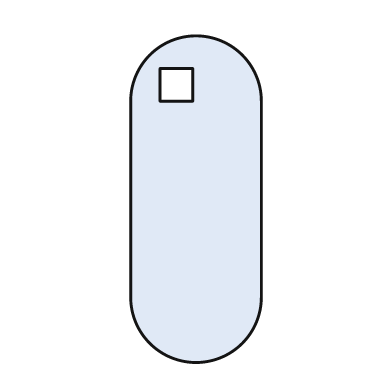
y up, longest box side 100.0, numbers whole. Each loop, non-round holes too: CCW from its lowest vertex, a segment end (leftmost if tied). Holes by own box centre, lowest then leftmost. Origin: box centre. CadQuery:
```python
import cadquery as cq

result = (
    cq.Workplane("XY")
    .moveTo(-20.0, -30.0)
    .threePointArc((0.0, -50.0), (20.0, -30.0))
    .lineTo(20.0, 30.0)
    .threePointArc((0.0, 50.0), (-20.0, 30.0))
    .close()
    .moveTo(-11.0, 30.0)
    .lineTo(-1.0, 30.0)
    .lineTo(-1.0, 40.0)
    .lineTo(-11.0, 40.0)
    .close()
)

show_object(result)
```